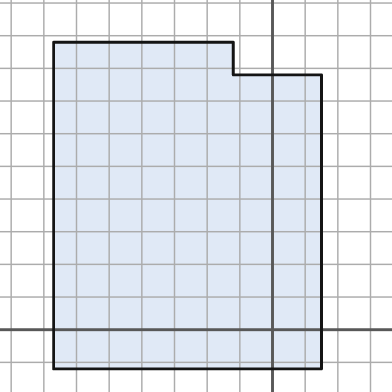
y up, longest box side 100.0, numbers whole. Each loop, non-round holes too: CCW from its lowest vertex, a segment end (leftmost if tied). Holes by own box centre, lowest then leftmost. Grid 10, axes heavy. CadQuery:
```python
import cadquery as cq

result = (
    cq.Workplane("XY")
    .moveTo(-67.0, -12.0)
    .lineTo(15.0, -12.0)
    .lineTo(15.0, 78.0)
    .lineTo(-12.0, 78.0)
    .lineTo(-12.0, 88.0)
    .lineTo(-67.0, 88.0)
    .close()
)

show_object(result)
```